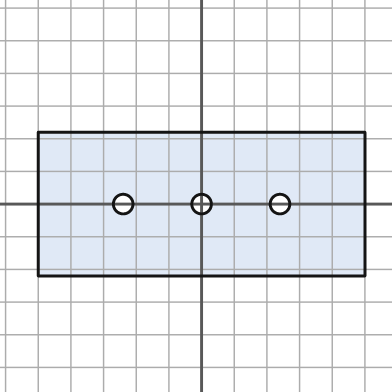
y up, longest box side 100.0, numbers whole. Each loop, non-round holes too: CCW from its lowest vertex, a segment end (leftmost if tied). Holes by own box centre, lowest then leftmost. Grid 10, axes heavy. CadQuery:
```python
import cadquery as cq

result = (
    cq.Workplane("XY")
    .moveTo(-50.0, -22.0)
    .lineTo(50.0, -22.0)
    .lineTo(50.0, 22.0)
    .lineTo(-50.0, 22.0)
    .close()
    .moveTo(-24.0, 0.0)
    .circle(3.0)
    .moveTo(0.0, 0.0)
    .circle(3.0)
    .moveTo(24.0, 0.0)
    .circle(3.0)
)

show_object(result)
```